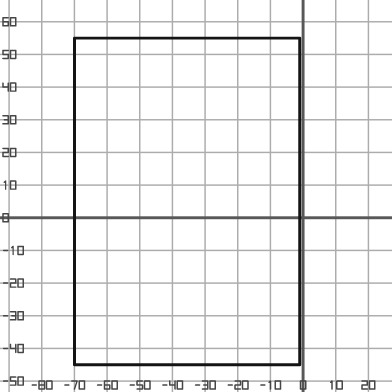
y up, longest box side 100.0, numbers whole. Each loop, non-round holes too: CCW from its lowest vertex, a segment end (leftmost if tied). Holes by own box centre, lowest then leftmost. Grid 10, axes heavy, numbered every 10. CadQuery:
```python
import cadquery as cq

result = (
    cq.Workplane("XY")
    .moveTo(-70.0, -45.0)
    .lineTo(-1.0, -45.0)
    .lineTo(-1.0, 55.0)
    .lineTo(-70.0, 55.0)
    .close()
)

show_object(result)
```